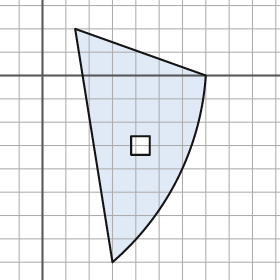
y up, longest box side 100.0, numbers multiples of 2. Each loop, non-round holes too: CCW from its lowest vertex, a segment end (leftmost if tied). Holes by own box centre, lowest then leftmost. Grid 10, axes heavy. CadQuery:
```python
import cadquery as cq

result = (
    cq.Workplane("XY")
    .moveTo(30.0, -80.0)
    .threePointArc((58.0, -44.0), (70.0, 0.0))
    .lineTo(14.0, 20.0)
    .close()
    .moveTo(38.0, -34.0)
    .lineTo(46.0, -34.0)
    .lineTo(46.0, -26.0)
    .lineTo(38.0, -26.0)
    .close()
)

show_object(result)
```